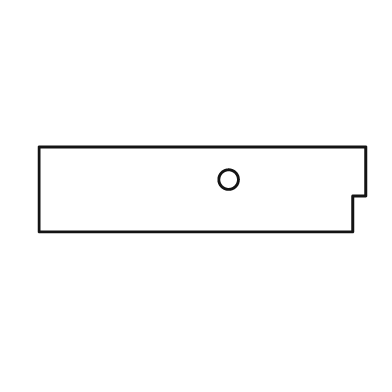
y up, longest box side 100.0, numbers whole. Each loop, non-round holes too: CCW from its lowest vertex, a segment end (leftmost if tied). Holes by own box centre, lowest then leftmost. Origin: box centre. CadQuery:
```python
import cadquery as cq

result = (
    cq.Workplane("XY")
    .moveTo(-50.0, -13.0)
    .lineTo(46.0, -13.0)
    .lineTo(46.0, -2.0)
    .lineTo(50.0, -2.0)
    .lineTo(50.0, 13.0)
    .lineTo(-50.0, 13.0)
    .close()
    .moveTo(8.0, 3.0)
    .circle(3.0)
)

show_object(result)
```